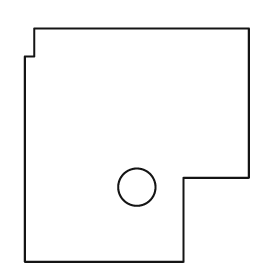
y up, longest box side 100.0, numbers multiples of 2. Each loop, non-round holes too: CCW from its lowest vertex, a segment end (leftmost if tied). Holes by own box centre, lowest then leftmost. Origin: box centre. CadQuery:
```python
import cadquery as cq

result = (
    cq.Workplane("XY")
    .moveTo(-48.0, -50.0)
    .lineTo(20.0, -50.0)
    .lineTo(20.0, -14.0)
    .lineTo(48.0, -14.0)
    .lineTo(48.0, 50.0)
    .lineTo(-44.0, 50.0)
    .lineTo(-44.0, 38.0)
    .lineTo(-48.0, 38.0)
    .close()
    .moveTo(0.0, -18.0)
    .circle(8.0)
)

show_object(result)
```